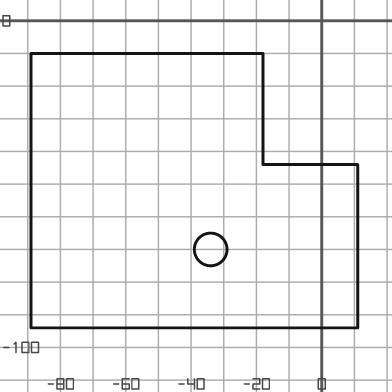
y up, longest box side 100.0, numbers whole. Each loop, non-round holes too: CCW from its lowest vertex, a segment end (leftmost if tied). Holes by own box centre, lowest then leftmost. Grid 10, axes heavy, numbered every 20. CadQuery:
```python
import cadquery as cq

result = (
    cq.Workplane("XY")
    .moveTo(-89.0, -94.0)
    .lineTo(11.0, -94.0)
    .lineTo(11.0, -44.0)
    .lineTo(-18.0, -44.0)
    .lineTo(-18.0, -10.0)
    .lineTo(-89.0, -10.0)
    .close()
    .moveTo(-34.0, -70.0)
    .circle(5.0)
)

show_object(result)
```